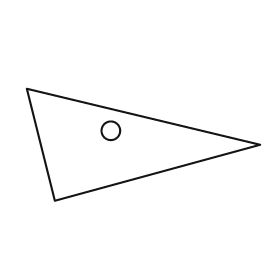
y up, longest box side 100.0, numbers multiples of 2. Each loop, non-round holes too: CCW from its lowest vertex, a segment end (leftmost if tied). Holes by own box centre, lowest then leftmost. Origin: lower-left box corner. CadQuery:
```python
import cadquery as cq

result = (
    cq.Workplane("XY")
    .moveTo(12.0, 0.0)
    .lineTo(100.0, 24.0)
    .lineTo(0.0, 48.0)
    .close()
    .moveTo(36.0, 30.0)
    .circle(4.0)
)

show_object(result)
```